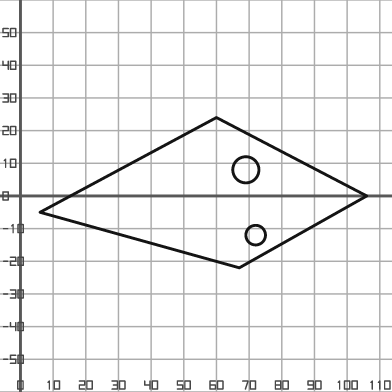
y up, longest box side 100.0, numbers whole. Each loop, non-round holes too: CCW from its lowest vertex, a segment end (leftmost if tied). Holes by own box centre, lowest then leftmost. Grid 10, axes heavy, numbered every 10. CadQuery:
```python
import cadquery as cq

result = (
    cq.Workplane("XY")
    .moveTo(67.0, -22.0)
    .lineTo(106.0, 0.0)
    .lineTo(60.0, 24.0)
    .lineTo(6.0, -5.0)
    .close()
    .moveTo(72.0, -12.0)
    .circle(3.0)
    .moveTo(69.0, 8.0)
    .circle(4.0)
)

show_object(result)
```